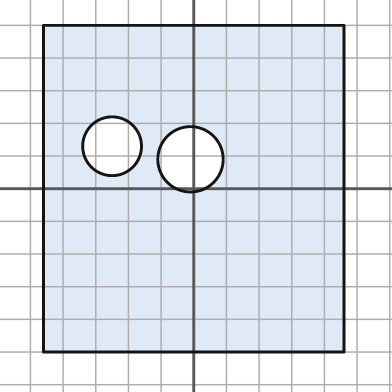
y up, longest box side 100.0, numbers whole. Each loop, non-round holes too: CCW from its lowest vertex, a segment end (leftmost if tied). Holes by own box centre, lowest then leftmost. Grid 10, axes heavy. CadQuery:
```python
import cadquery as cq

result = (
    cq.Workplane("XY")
    .moveTo(-46.0, -50.0)
    .lineTo(46.0, -50.0)
    .lineTo(46.0, 50.0)
    .lineTo(-46.0, 50.0)
    .close()
    .moveTo(-1.0, 9.0)
    .circle(10.0)
    .moveTo(-25.0, 13.0)
    .circle(9.0)
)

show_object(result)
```